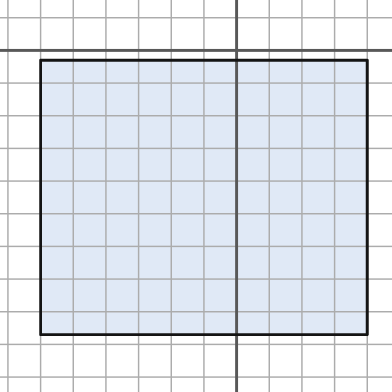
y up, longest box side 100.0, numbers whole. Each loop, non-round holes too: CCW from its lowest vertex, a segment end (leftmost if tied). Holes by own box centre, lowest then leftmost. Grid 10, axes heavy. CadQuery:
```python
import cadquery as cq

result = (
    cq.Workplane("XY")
    .moveTo(-60.0, -87.0)
    .lineTo(40.0, -87.0)
    .lineTo(40.0, -3.0)
    .lineTo(-60.0, -3.0)
    .close()
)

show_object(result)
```